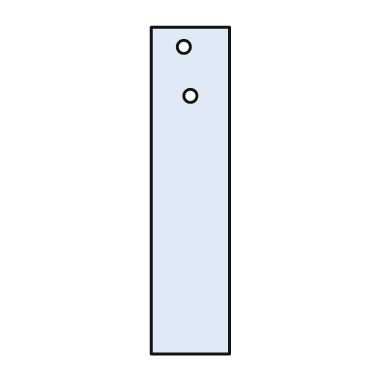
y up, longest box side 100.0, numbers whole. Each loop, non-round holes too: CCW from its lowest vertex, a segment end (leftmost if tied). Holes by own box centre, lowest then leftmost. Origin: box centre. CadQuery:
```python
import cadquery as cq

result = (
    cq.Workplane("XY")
    .moveTo(-12.0, -50.0)
    .lineTo(12.0, -50.0)
    .lineTo(12.0, 50.0)
    .lineTo(-12.0, 50.0)
    .close()
    .moveTo(0.0, 29.0)
    .circle(2.0)
    .moveTo(-2.0, 44.0)
    .circle(2.0)
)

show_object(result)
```